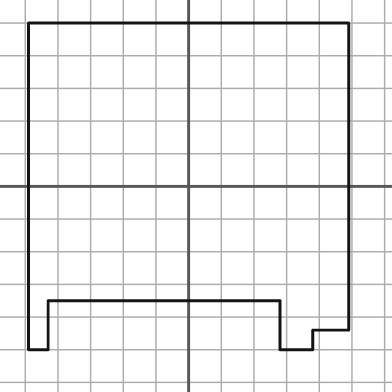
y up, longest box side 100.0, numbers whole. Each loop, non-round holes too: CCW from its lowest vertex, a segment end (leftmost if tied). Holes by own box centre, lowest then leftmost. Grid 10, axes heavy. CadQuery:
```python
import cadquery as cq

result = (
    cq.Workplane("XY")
    .moveTo(-49.0, -50.0)
    .lineTo(-43.0, -50.0)
    .lineTo(-43.0, -35.0)
    .lineTo(28.0, -35.0)
    .lineTo(28.0, -50.0)
    .lineTo(38.0, -50.0)
    .lineTo(38.0, -44.0)
    .lineTo(49.0, -44.0)
    .lineTo(49.0, 50.0)
    .lineTo(-49.0, 50.0)
    .close()
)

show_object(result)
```